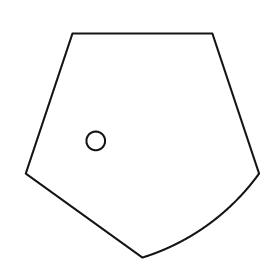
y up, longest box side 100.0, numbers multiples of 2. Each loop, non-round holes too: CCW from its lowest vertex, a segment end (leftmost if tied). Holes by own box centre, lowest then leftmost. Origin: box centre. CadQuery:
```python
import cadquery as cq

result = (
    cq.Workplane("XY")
    .moveTo(0.0, -48.0)
    .threePointArc((28.0, -34.0), (50.0, -12.0))
    .lineTo(30.0, 48.0)
    .lineTo(-30.0, 48.0)
    .lineTo(-50.0, -12.0)
    .close()
    .moveTo(-20.0, 2.0)
    .circle(4.0)
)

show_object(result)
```